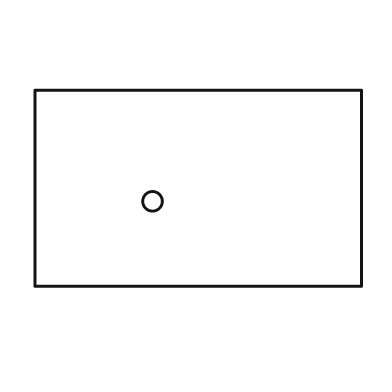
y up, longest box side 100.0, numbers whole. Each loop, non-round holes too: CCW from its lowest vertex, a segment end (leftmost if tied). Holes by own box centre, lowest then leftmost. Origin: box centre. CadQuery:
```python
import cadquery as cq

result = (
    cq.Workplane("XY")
    .moveTo(-50.0, -30.0)
    .lineTo(50.0, -30.0)
    .lineTo(50.0, 30.0)
    .lineTo(-50.0, 30.0)
    .close()
    .moveTo(-14.0, -4.0)
    .circle(3.0)
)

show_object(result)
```